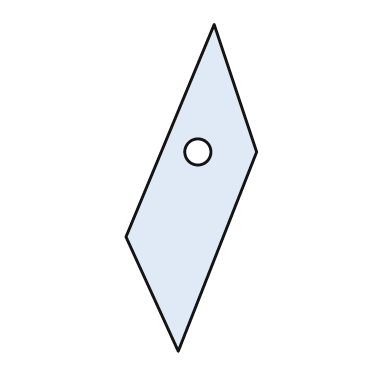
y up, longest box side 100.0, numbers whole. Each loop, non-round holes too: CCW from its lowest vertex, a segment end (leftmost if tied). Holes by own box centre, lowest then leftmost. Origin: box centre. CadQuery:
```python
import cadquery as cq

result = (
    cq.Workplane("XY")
    .moveTo(-4.0, -50.0)
    .lineTo(20.0, 11.0)
    .lineTo(7.0, 50.0)
    .lineTo(-20.0, -15.0)
    .close()
    .moveTo(2.0, 11.0)
    .circle(4.0)
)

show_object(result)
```